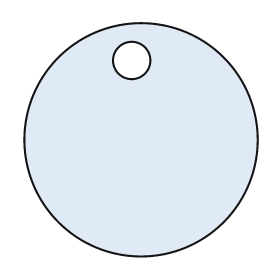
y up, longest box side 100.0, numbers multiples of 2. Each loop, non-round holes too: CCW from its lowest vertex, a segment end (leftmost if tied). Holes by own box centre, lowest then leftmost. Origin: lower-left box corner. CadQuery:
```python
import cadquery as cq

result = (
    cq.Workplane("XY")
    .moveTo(50.0, 50.0)
    .circle(50.0)
    .moveTo(46.0, 84.0)
    .circle(8.0)
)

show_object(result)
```